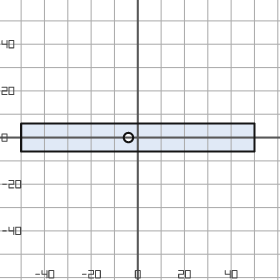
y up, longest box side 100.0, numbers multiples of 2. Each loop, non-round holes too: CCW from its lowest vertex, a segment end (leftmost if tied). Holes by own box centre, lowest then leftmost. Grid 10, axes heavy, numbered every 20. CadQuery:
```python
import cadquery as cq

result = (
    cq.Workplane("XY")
    .moveTo(-50.0, -6.0)
    .lineTo(50.0, -6.0)
    .lineTo(50.0, 6.0)
    .lineTo(-50.0, 6.0)
    .close()
    .moveTo(-4.0, 0.0)
    .circle(2.0)
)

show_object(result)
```